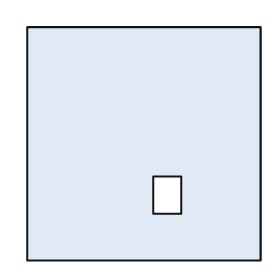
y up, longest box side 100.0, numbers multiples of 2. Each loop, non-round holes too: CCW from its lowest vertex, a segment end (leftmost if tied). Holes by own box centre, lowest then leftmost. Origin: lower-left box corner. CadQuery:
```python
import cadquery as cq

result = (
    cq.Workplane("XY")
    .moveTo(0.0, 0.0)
    .lineTo(100.0, 0.0)
    .lineTo(100.0, 100.0)
    .lineTo(0.0, 100.0)
    .close()
    .moveTo(54.0, 20.0)
    .lineTo(66.0, 20.0)
    .lineTo(66.0, 36.0)
    .lineTo(54.0, 36.0)
    .close()
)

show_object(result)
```